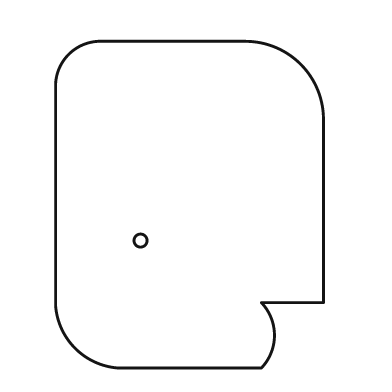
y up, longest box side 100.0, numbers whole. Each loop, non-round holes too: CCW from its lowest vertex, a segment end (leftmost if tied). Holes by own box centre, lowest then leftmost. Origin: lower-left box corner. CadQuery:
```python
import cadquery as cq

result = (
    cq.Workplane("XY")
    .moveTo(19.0, 0.0)
    .lineTo(63.0, 0.0)
    .threePointArc((67.0, 10.0), (63.0, 20.0))
    .lineTo(82.0, 20.0)
    .lineTo(82.0, 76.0)
    .threePointArc((75.0, 93.0), (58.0, 100.0))
    .lineTo(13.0, 100.0)
    .threePointArc((4.0, 96.0), (0.0, 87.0))
    .lineTo(0.0, 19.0)
    .threePointArc((6.0, 6.0), (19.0, 0.0))
    .close()
    .moveTo(26.0, 39.0)
    .circle(2.0)
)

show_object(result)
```